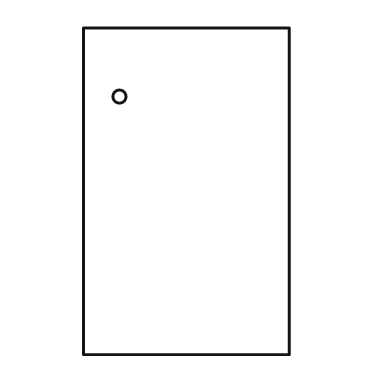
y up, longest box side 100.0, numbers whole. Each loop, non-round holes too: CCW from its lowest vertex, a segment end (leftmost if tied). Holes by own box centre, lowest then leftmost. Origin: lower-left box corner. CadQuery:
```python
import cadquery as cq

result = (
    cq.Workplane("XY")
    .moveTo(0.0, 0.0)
    .lineTo(63.0, 0.0)
    .lineTo(63.0, 100.0)
    .lineTo(0.0, 100.0)
    .close()
    .moveTo(11.0, 79.0)
    .circle(2.0)
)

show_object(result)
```